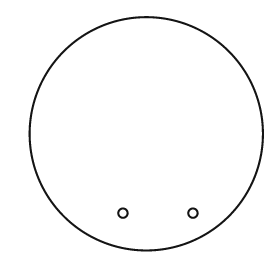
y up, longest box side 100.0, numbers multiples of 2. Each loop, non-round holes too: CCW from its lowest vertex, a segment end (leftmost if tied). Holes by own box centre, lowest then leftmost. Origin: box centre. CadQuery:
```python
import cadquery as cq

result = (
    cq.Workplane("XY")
    .moveTo(0.0, 0.0)
    .circle(50.0)
    .moveTo(-10.0, -34.0)
    .circle(2.0)
    .moveTo(20.0, -34.0)
    .circle(2.0)
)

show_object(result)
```